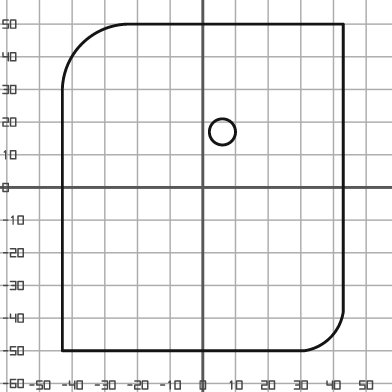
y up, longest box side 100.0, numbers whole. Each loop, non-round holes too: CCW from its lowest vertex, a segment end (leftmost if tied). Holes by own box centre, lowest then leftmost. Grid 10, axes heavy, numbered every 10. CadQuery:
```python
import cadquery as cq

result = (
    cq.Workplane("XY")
    .moveTo(-43.0, -50.0)
    .lineTo(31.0, -50.0)
    .threePointArc((39.0, -46.0), (43.0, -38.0))
    .lineTo(43.0, 50.0)
    .lineTo(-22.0, 50.0)
    .threePointArc((-37.0, 44.0), (-43.0, 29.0))
    .close()
    .moveTo(6.0, 17.0)
    .circle(4.0)
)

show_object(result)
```